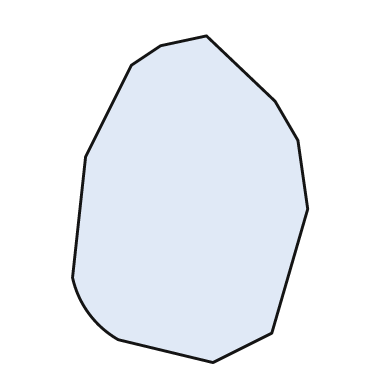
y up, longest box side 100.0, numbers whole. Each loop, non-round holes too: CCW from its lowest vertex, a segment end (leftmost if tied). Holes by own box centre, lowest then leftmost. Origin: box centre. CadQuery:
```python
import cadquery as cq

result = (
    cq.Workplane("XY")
    .moveTo(7.0, -50.0)
    .lineTo(25.0, -41.0)
    .lineTo(36.0, -3.0)
    .lineTo(33.0, 18.0)
    .lineTo(26.0, 30.0)
    .lineTo(5.0, 50.0)
    .lineTo(-9.0, 47.0)
    .lineTo(-18.0, 41.0)
    .lineTo(-32.0, 13.0)
    .lineTo(-36.0, -24.0)
    .threePointArc((-31.0, -35.0), (-22.0, -43.0))
    .close()
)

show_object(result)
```